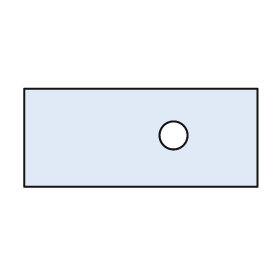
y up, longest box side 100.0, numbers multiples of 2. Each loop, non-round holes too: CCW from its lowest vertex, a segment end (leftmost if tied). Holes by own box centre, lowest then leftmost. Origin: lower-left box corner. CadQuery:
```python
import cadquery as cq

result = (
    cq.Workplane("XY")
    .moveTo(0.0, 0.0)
    .lineTo(100.0, 0.0)
    .lineTo(100.0, 42.0)
    .lineTo(0.0, 42.0)
    .close()
    .moveTo(64.0, 22.0)
    .circle(6.0)
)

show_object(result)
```